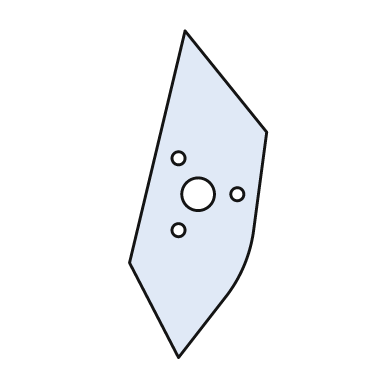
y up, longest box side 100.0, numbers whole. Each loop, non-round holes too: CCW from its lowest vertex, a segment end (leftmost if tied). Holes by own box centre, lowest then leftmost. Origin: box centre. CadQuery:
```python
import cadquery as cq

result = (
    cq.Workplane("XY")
    .moveTo(-6.0, -50.0)
    .lineTo(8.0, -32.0)
    .threePointArc((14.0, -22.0), (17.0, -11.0))
    .lineTo(21.0, 19.0)
    .lineTo(-4.0, 50.0)
    .lineTo(-21.0, -21.0)
    .close()
    .moveTo(-6.0, -11.0)
    .circle(2.0)
    .moveTo(0.0, 0.0)
    .circle(5.0)
    .moveTo(12.0, 0.0)
    .circle(2.0)
    .moveTo(-6.0, 11.0)
    .circle(2.0)
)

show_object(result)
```